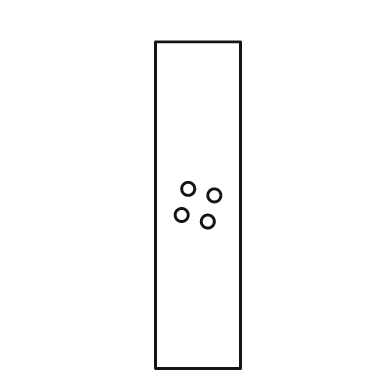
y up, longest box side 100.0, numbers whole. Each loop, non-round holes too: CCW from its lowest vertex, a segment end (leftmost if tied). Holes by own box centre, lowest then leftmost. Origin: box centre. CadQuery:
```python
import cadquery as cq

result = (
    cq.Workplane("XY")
    .moveTo(-13.0, -50.0)
    .lineTo(13.0, -50.0)
    .lineTo(13.0, 50.0)
    .lineTo(-13.0, 50.0)
    .close()
    .moveTo(3.0, -5.0)
    .circle(2.0)
    .moveTo(-5.0, -3.0)
    .circle(2.0)
    .moveTo(5.0, 3.0)
    .circle(2.0)
    .moveTo(-3.0, 5.0)
    .circle(2.0)
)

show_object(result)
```